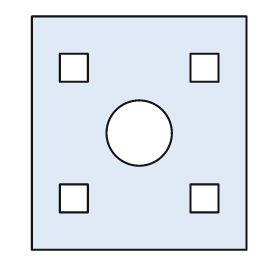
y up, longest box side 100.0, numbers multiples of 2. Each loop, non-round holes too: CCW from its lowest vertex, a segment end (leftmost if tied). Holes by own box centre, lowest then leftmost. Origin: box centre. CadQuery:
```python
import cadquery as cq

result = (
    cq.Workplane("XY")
    .moveTo(-46.0, -50.0)
    .lineTo(46.0, -50.0)
    .lineTo(46.0, 50.0)
    .lineTo(-46.0, 50.0)
    .close()
    .moveTo(-34.0, -34.0)
    .lineTo(-22.0, -34.0)
    .lineTo(-22.0, -22.0)
    .lineTo(-34.0, -22.0)
    .close()
    .moveTo(22.0, -34.0)
    .lineTo(34.0, -34.0)
    .lineTo(34.0, -22.0)
    .lineTo(22.0, -22.0)
    .close()
    .moveTo(0.0, 0.0)
    .circle(14.0)
    .moveTo(-34.0, 22.0)
    .lineTo(-22.0, 22.0)
    .lineTo(-22.0, 34.0)
    .lineTo(-34.0, 34.0)
    .close()
    .moveTo(22.0, 22.0)
    .lineTo(34.0, 22.0)
    .lineTo(34.0, 34.0)
    .lineTo(22.0, 34.0)
    .close()
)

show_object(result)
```